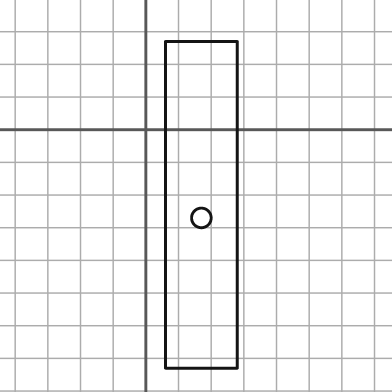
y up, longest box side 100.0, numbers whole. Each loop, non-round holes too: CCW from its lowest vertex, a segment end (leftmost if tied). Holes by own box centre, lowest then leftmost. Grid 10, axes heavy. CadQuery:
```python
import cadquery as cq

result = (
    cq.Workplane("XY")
    .moveTo(6.0, -73.0)
    .lineTo(28.0, -73.0)
    .lineTo(28.0, 27.0)
    .lineTo(6.0, 27.0)
    .close()
    .moveTo(17.0, -27.0)
    .circle(3.0)
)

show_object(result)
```